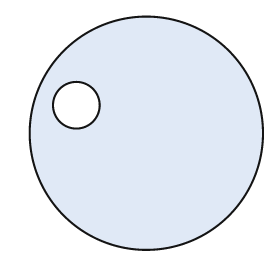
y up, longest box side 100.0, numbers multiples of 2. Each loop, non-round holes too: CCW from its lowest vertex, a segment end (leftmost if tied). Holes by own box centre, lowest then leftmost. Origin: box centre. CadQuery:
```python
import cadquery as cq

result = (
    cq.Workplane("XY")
    .moveTo(0.0, 0.0)
    .circle(50.0)
    .moveTo(-30.0, 12.0)
    .circle(10.0)
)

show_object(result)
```